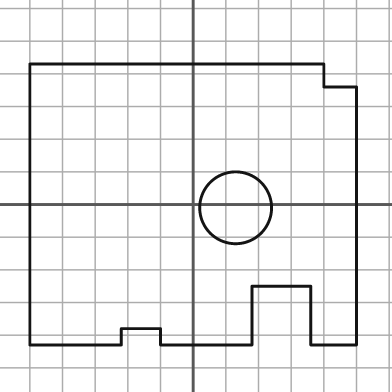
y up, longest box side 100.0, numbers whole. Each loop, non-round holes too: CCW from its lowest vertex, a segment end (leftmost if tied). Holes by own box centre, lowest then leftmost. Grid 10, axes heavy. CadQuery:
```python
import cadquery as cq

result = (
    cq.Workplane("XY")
    .moveTo(-50.0, -43.0)
    .lineTo(-22.0, -43.0)
    .lineTo(-22.0, -38.0)
    .lineTo(-10.0, -38.0)
    .lineTo(-10.0, -43.0)
    .lineTo(18.0, -43.0)
    .lineTo(18.0, -25.0)
    .lineTo(36.0, -25.0)
    .lineTo(36.0, -43.0)
    .lineTo(50.0, -43.0)
    .lineTo(50.0, 36.0)
    .lineTo(40.0, 36.0)
    .lineTo(40.0, 43.0)
    .lineTo(-50.0, 43.0)
    .close()
    .moveTo(13.0, -1.0)
    .circle(11.0)
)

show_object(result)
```